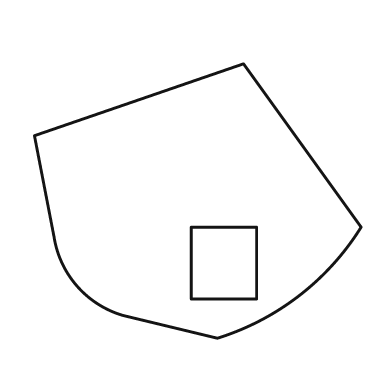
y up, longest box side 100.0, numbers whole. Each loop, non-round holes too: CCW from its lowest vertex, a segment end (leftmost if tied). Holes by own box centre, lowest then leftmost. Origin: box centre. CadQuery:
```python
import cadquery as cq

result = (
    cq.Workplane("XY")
    .moveTo(6.0, -42.0)
    .threePointArc((31.0, -29.0), (50.0, -8.0))
    .lineTo(14.0, 42.0)
    .lineTo(-50.0, 20.0)
    .lineTo(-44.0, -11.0)
    .threePointArc((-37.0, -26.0), (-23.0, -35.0))
    .close()
    .moveTo(-2.0, -30.0)
    .lineTo(18.0, -30.0)
    .lineTo(18.0, -8.0)
    .lineTo(-2.0, -8.0)
    .close()
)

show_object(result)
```